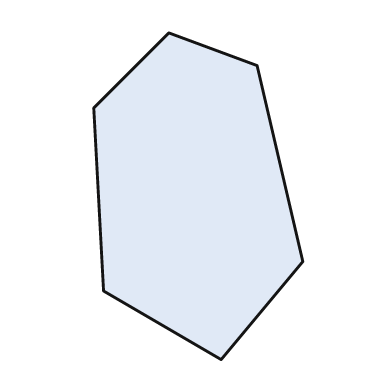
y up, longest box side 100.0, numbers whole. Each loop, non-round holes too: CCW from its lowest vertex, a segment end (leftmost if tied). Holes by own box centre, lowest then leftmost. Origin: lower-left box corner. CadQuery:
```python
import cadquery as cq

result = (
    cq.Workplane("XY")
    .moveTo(39.0, 0.0)
    .lineTo(64.0, 30.0)
    .lineTo(50.0, 90.0)
    .lineTo(23.0, 100.0)
    .lineTo(0.0, 77.0)
    .lineTo(3.0, 21.0)
    .close()
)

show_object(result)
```